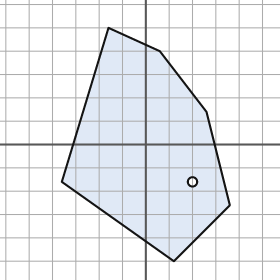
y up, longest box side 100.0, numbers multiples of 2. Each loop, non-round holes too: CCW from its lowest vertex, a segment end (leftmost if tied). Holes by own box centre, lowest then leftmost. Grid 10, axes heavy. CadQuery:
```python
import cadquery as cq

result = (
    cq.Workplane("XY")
    .moveTo(12.0, -50.0)
    .lineTo(36.0, -26.0)
    .lineTo(26.0, 14.0)
    .lineTo(6.0, 40.0)
    .lineTo(-16.0, 50.0)
    .lineTo(-36.0, -16.0)
    .close()
    .moveTo(20.0, -16.0)
    .circle(2.0)
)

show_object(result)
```